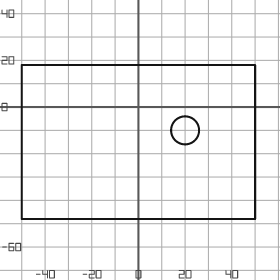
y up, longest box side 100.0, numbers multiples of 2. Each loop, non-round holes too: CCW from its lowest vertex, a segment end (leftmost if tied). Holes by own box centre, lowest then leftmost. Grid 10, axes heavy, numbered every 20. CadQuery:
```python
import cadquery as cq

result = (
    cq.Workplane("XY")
    .moveTo(-50.0, -48.0)
    .lineTo(50.0, -48.0)
    .lineTo(50.0, 18.0)
    .lineTo(-50.0, 18.0)
    .close()
    .moveTo(20.0, -10.0)
    .circle(6.0)
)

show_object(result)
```